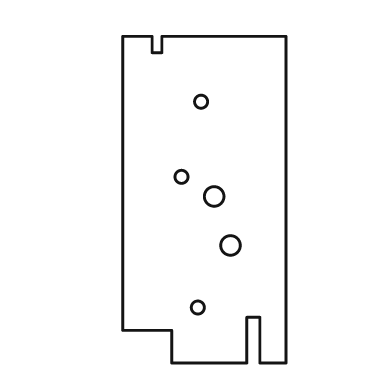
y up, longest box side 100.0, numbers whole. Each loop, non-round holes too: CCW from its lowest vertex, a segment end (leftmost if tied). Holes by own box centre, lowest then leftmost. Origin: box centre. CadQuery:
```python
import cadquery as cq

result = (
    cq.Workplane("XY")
    .moveTo(-10.0, -50.0)
    .lineTo(13.0, -50.0)
    .lineTo(13.0, -36.0)
    .lineTo(17.0, -36.0)
    .lineTo(17.0, -50.0)
    .lineTo(25.0, -50.0)
    .lineTo(25.0, 50.0)
    .lineTo(-13.0, 50.0)
    .lineTo(-13.0, 45.0)
    .lineTo(-16.0, 45.0)
    .lineTo(-16.0, 50.0)
    .lineTo(-25.0, 50.0)
    .lineTo(-25.0, -40.0)
    .lineTo(-10.0, -40.0)
    .close()
    .moveTo(-2.0, -33.0)
    .circle(2.0)
    .moveTo(8.0, -14.0)
    .circle(3.0)
    .moveTo(3.0, 1.0)
    .circle(3.0)
    .moveTo(-7.0, 7.0)
    .circle(2.0)
    .moveTo(-1.0, 30.0)
    .circle(2.0)
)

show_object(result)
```